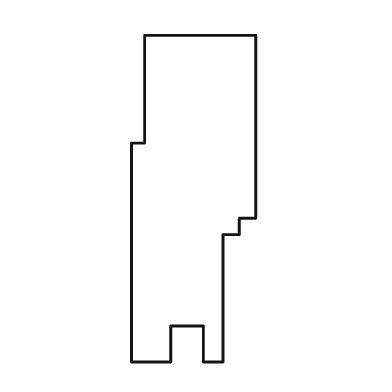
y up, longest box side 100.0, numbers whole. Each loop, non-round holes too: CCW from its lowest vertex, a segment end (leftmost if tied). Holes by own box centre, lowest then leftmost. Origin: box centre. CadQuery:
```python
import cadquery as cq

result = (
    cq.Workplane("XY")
    .moveTo(-19.0, -50.0)
    .lineTo(-7.0, -50.0)
    .lineTo(-7.0, -39.0)
    .lineTo(3.0, -39.0)
    .lineTo(3.0, -50.0)
    .lineTo(9.0, -50.0)
    .lineTo(9.0, -11.0)
    .lineTo(14.0, -11.0)
    .lineTo(14.0, -6.0)
    .lineTo(19.0, -6.0)
    .lineTo(19.0, 50.0)
    .lineTo(-15.0, 50.0)
    .lineTo(-15.0, 17.0)
    .lineTo(-19.0, 17.0)
    .close()
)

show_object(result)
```